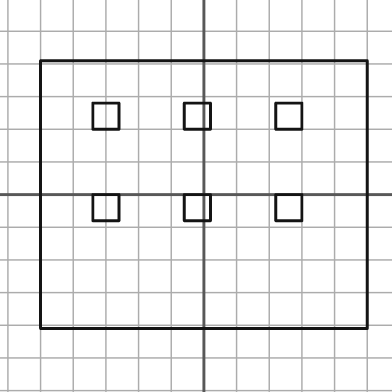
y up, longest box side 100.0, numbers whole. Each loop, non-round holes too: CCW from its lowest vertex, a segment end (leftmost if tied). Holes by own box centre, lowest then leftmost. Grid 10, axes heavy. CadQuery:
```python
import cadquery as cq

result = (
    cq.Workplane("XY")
    .moveTo(-50.0, -41.0)
    .lineTo(50.0, -41.0)
    .lineTo(50.0, 41.0)
    .lineTo(-50.0, 41.0)
    .close()
    .moveTo(-34.0, -8.0)
    .lineTo(-26.0, -8.0)
    .lineTo(-26.0, 0.0)
    .lineTo(-34.0, 0.0)
    .close()
    .moveTo(-6.0, -8.0)
    .lineTo(2.0, -8.0)
    .lineTo(2.0, 0.0)
    .lineTo(-6.0, 0.0)
    .close()
    .moveTo(22.0, -8.0)
    .lineTo(30.0, -8.0)
    .lineTo(30.0, 0.0)
    .lineTo(22.0, 0.0)
    .close()
    .moveTo(-34.0, 20.0)
    .lineTo(-26.0, 20.0)
    .lineTo(-26.0, 28.0)
    .lineTo(-34.0, 28.0)
    .close()
    .moveTo(-6.0, 20.0)
    .lineTo(2.0, 20.0)
    .lineTo(2.0, 28.0)
    .lineTo(-6.0, 28.0)
    .close()
    .moveTo(22.0, 20.0)
    .lineTo(30.0, 20.0)
    .lineTo(30.0, 28.0)
    .lineTo(22.0, 28.0)
    .close()
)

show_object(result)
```